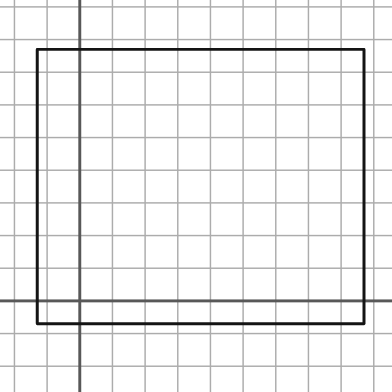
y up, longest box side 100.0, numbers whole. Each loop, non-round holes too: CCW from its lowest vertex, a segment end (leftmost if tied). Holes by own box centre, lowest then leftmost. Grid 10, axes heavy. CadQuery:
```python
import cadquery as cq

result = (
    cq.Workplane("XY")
    .moveTo(-13.0, -7.0)
    .lineTo(87.0, -7.0)
    .lineTo(87.0, 77.0)
    .lineTo(-13.0, 77.0)
    .close()
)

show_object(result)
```